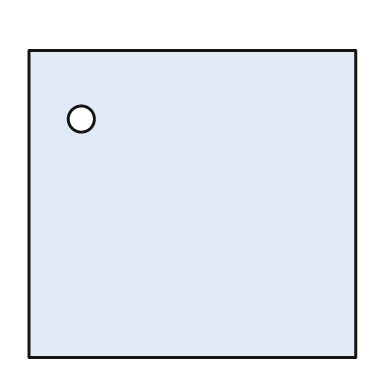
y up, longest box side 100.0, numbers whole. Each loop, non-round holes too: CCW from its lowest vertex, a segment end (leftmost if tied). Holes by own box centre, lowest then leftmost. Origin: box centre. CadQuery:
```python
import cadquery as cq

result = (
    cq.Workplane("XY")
    .moveTo(-50.0, -47.0)
    .lineTo(50.0, -47.0)
    .lineTo(50.0, 47.0)
    .lineTo(-50.0, 47.0)
    .close()
    .moveTo(-34.0, 26.0)
    .circle(4.0)
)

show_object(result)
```